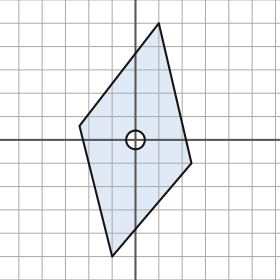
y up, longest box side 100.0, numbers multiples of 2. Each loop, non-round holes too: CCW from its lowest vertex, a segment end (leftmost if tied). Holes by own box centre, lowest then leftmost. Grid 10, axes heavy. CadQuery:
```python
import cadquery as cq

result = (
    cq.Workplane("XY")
    .moveTo(-10.0, -50.0)
    .lineTo(24.0, -10.0)
    .lineTo(10.0, 50.0)
    .lineTo(-24.0, 6.0)
    .close()
    .moveTo(0.0, 0.0)
    .circle(4.0)
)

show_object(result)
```